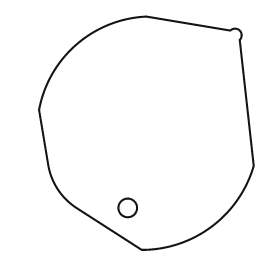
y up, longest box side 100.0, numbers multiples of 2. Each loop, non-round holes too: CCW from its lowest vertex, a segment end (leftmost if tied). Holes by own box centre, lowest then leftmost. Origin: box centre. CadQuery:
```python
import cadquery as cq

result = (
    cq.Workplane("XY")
    .moveTo(-2.0, -50.0)
    .threePointArc((28.0, -40.0), (46.0, -14.0))
    .lineTo(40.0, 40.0)
    .threePointArc((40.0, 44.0), (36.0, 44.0))
    .lineTo(0.0, 50.0)
    .threePointArc((-30.0, 38.0), (-46.0, 10.0))
    .lineTo(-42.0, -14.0)
    .threePointArc((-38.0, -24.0), (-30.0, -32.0))
    .close()
    .moveTo(-8.0, -32.0)
    .circle(4.0)
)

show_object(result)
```